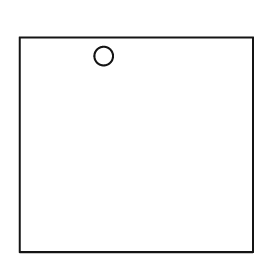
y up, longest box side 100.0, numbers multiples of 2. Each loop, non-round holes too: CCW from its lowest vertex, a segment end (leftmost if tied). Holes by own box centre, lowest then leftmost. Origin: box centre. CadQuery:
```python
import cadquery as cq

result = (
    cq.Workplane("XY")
    .moveTo(-50.0, -46.0)
    .lineTo(50.0, -46.0)
    .lineTo(50.0, 46.0)
    .lineTo(-50.0, 46.0)
    .close()
    .moveTo(-14.0, 38.0)
    .circle(4.0)
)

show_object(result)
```